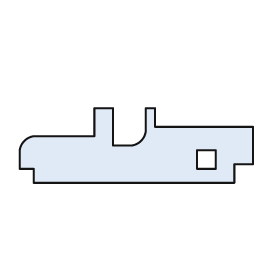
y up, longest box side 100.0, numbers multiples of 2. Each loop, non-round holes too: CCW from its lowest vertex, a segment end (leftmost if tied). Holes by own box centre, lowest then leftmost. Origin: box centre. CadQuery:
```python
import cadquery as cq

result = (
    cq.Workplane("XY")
    .moveTo(-44.0, -16.0)
    .lineTo(42.0, -16.0)
    .lineTo(42.0, -8.0)
    .lineTo(50.0, -8.0)
    .lineTo(50.0, 8.0)
    .lineTo(8.0, 8.0)
    .lineTo(8.0, 16.0)
    .lineTo(4.0, 16.0)
    .lineTo(4.0, 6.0)
    .threePointArc((2.0, 2.0), (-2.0, 0.0))
    .lineTo(-10.0, 0.0)
    .lineTo(-10.0, 16.0)
    .lineTo(-18.0, 16.0)
    .lineTo(-18.0, 4.0)
    .lineTo(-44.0, 4.0)
    .threePointArc((-48.0, 2.0), (-50.0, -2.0))
    .lineTo(-50.0, -10.0)
    .lineTo(-44.0, -10.0)
    .close()
    .moveTo(26.0, -10.0)
    .lineTo(34.0, -10.0)
    .lineTo(34.0, -2.0)
    .lineTo(26.0, -2.0)
    .close()
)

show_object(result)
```